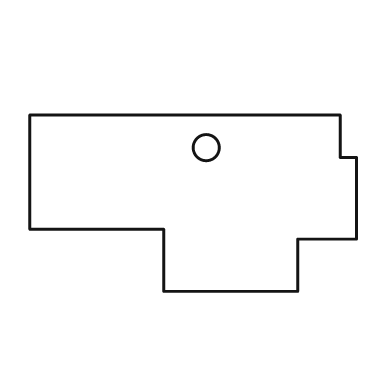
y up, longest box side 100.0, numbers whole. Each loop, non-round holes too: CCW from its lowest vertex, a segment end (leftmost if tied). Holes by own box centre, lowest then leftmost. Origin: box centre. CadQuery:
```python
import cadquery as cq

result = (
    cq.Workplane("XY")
    .moveTo(-9.0, -27.0)
    .lineTo(32.0, -27.0)
    .lineTo(32.0, -11.0)
    .lineTo(50.0, -11.0)
    .lineTo(50.0, 14.0)
    .lineTo(45.0, 14.0)
    .lineTo(45.0, 27.0)
    .lineTo(-50.0, 27.0)
    .lineTo(-50.0, -8.0)
    .lineTo(-9.0, -8.0)
    .close()
    .moveTo(4.0, 17.0)
    .circle(4.0)
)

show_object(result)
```